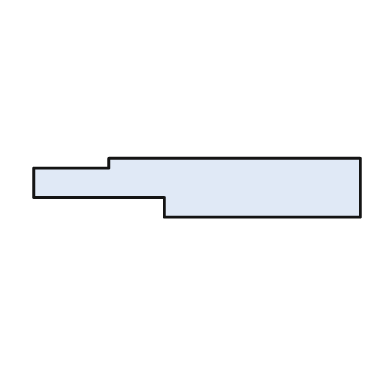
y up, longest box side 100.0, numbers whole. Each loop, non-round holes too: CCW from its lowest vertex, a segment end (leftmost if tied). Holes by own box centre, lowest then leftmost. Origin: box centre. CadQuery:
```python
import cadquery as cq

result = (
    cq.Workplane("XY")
    .moveTo(-10.0, -9.0)
    .lineTo(50.0, -9.0)
    .lineTo(50.0, 9.0)
    .lineTo(-27.0, 9.0)
    .lineTo(-27.0, 6.0)
    .lineTo(-50.0, 6.0)
    .lineTo(-50.0, -3.0)
    .lineTo(-10.0, -3.0)
    .close()
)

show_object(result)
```